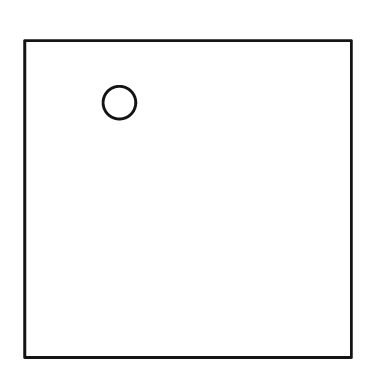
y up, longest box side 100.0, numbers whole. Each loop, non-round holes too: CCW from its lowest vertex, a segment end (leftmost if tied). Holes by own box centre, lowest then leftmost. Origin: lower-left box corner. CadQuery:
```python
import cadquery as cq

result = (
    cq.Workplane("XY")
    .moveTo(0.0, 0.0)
    .lineTo(100.0, 0.0)
    .lineTo(100.0, 97.0)
    .lineTo(0.0, 97.0)
    .close()
    .moveTo(29.0, 78.0)
    .circle(5.0)
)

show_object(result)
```